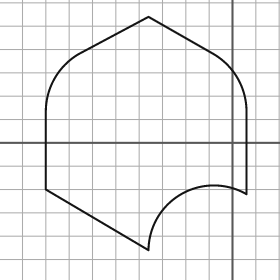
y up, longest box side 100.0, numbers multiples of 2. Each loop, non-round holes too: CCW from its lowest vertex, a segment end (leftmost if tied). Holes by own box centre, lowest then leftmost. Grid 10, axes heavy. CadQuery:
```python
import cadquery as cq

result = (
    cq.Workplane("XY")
    .moveTo(-36.0, -46.0)
    .threePointArc((-22.0, -22.0), (6.0, -22.0))
    .lineTo(6.0, 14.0)
    .threePointArc((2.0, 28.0), (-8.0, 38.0))
    .lineTo(-36.0, 54.0)
    .lineTo(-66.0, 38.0)
    .threePointArc((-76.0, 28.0), (-80.0, 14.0))
    .lineTo(-80.0, -20.0)
    .close()
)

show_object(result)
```